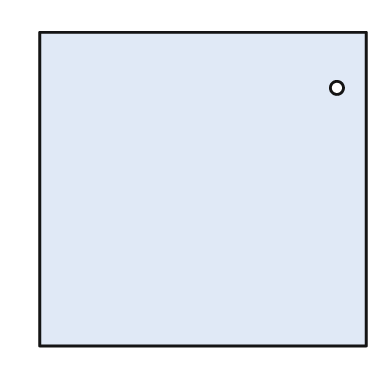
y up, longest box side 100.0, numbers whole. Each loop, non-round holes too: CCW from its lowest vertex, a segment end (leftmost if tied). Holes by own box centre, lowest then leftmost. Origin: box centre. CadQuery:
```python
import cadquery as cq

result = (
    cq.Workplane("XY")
    .moveTo(-50.0, -48.0)
    .lineTo(50.0, -48.0)
    .lineTo(50.0, 48.0)
    .lineTo(-50.0, 48.0)
    .close()
    .moveTo(41.0, 31.0)
    .circle(2.0)
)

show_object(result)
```